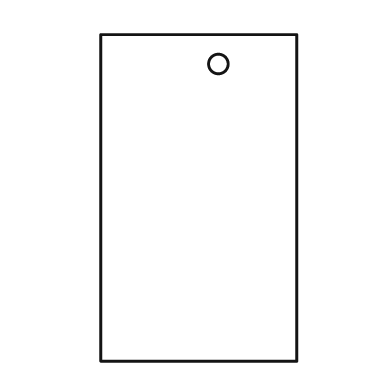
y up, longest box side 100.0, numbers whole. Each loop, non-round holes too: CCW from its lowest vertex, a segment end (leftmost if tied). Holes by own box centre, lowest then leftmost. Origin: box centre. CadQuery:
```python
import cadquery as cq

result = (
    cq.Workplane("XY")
    .moveTo(-30.0, -50.0)
    .lineTo(30.0, -50.0)
    .lineTo(30.0, 50.0)
    .lineTo(-30.0, 50.0)
    .close()
    .moveTo(6.0, 41.0)
    .circle(3.0)
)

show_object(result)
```